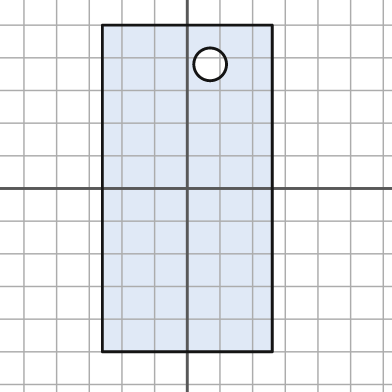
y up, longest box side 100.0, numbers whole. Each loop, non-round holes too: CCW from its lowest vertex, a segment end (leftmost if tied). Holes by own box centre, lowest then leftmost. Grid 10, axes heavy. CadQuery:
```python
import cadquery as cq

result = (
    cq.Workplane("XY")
    .moveTo(-26.0, -50.0)
    .lineTo(26.0, -50.0)
    .lineTo(26.0, 50.0)
    .lineTo(-26.0, 50.0)
    .close()
    .moveTo(7.0, 38.0)
    .circle(5.0)
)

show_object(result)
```